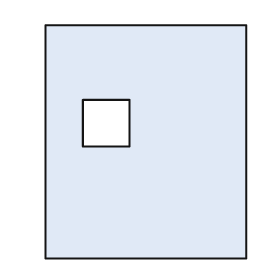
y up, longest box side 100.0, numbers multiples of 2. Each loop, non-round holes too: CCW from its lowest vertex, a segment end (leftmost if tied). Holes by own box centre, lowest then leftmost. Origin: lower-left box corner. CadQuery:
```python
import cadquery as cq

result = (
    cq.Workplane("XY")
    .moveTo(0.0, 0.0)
    .lineTo(86.0, 0.0)
    .lineTo(86.0, 100.0)
    .lineTo(0.0, 100.0)
    .close()
    .moveTo(16.0, 48.0)
    .lineTo(36.0, 48.0)
    .lineTo(36.0, 68.0)
    .lineTo(16.0, 68.0)
    .close()
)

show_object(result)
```